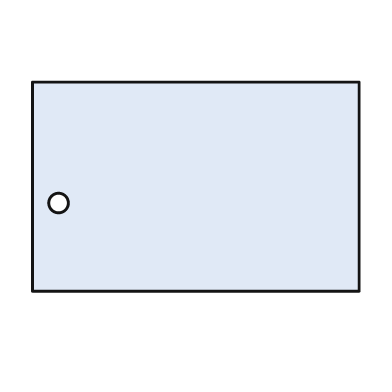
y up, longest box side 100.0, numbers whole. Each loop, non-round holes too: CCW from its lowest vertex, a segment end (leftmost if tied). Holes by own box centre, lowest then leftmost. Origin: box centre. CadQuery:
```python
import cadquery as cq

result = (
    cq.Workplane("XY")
    .moveTo(-50.0, -32.0)
    .lineTo(50.0, -32.0)
    .lineTo(50.0, 32.0)
    .lineTo(-50.0, 32.0)
    .close()
    .moveTo(-42.0, -5.0)
    .circle(3.0)
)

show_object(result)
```